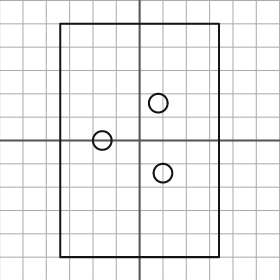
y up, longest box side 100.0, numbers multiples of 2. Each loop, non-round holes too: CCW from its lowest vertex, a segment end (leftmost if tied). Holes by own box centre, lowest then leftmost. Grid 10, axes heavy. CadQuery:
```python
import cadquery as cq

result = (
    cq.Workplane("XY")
    .moveTo(-34.0, -50.0)
    .lineTo(34.0, -50.0)
    .lineTo(34.0, 50.0)
    .lineTo(-34.0, 50.0)
    .close()
    .moveTo(10.0, -14.0)
    .circle(4.0)
    .moveTo(-16.0, 0.0)
    .circle(4.0)
    .moveTo(8.0, 16.0)
    .circle(4.0)
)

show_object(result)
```